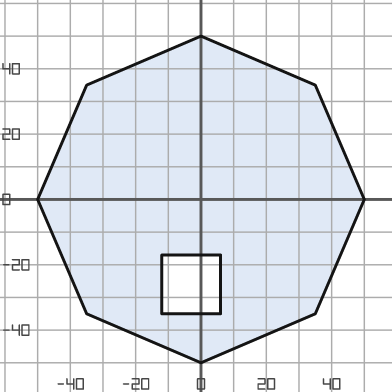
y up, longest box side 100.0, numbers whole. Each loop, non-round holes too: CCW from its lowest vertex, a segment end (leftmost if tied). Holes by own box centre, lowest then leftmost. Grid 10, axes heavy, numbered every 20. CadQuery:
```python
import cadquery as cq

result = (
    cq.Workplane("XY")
    .moveTo(0.0, -50.0)
    .lineTo(35.0, -35.0)
    .lineTo(50.0, 0.0)
    .lineTo(35.0, 35.0)
    .lineTo(0.0, 50.0)
    .lineTo(-35.0, 35.0)
    .lineTo(-50.0, 0.0)
    .lineTo(-35.0, -35.0)
    .close()
    .moveTo(-12.0, -35.0)
    .lineTo(6.0, -35.0)
    .lineTo(6.0, -17.0)
    .lineTo(-12.0, -17.0)
    .close()
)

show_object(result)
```